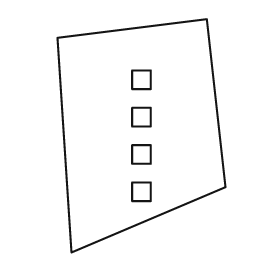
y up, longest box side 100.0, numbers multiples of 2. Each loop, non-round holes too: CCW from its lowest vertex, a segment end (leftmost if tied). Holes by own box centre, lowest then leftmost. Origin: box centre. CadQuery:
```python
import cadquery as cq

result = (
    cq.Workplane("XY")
    .moveTo(-30.0, -50.0)
    .lineTo(36.0, -22.0)
    .lineTo(28.0, 50.0)
    .lineTo(-36.0, 42.0)
    .close()
    .moveTo(-4.0, -28.0)
    .lineTo(4.0, -28.0)
    .lineTo(4.0, -20.0)
    .lineTo(-4.0, -20.0)
    .close()
    .moveTo(-4.0, -12.0)
    .lineTo(4.0, -12.0)
    .lineTo(4.0, -4.0)
    .lineTo(-4.0, -4.0)
    .close()
    .moveTo(-4.0, 4.0)
    .lineTo(4.0, 4.0)
    .lineTo(4.0, 12.0)
    .lineTo(-4.0, 12.0)
    .close()
    .moveTo(-4.0, 20.0)
    .lineTo(4.0, 20.0)
    .lineTo(4.0, 28.0)
    .lineTo(-4.0, 28.0)
    .close()
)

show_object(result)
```